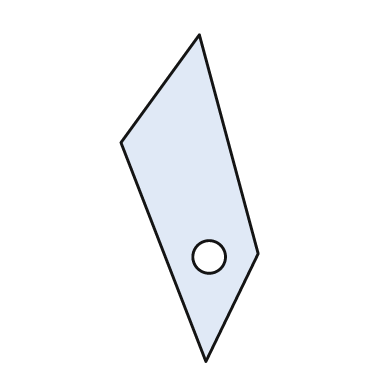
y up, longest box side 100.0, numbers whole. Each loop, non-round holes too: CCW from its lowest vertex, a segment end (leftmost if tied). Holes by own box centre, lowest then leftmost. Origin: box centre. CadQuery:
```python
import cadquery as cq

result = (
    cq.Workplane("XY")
    .moveTo(5.0, -50.0)
    .lineTo(21.0, -17.0)
    .lineTo(3.0, 50.0)
    .lineTo(-21.0, 17.0)
    .close()
    .moveTo(6.0, -18.0)
    .circle(5.0)
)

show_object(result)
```